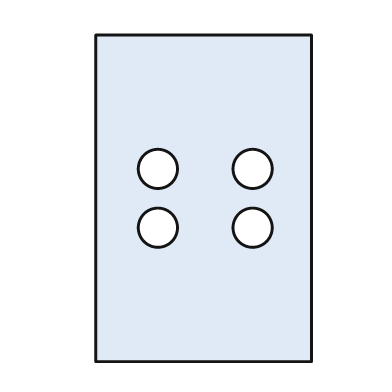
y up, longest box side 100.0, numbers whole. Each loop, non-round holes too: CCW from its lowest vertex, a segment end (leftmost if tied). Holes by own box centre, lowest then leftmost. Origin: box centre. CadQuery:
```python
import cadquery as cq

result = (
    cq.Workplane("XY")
    .moveTo(-33.0, -50.0)
    .lineTo(33.0, -50.0)
    .lineTo(33.0, 50.0)
    .lineTo(-33.0, 50.0)
    .close()
    .moveTo(-14.0, -9.0)
    .circle(6.0)
    .moveTo(15.0, -9.0)
    .circle(6.0)
    .moveTo(-14.0, 9.0)
    .circle(6.0)
    .moveTo(15.0, 9.0)
    .circle(6.0)
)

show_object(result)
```